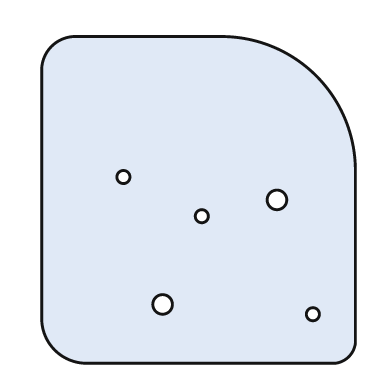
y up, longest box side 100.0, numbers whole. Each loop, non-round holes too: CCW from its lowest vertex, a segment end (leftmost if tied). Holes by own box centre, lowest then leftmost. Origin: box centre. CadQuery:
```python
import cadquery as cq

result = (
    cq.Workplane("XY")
    .moveTo(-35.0, -50.0)
    .lineTo(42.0, -50.0)
    .threePointArc((46.0, -48.0), (48.0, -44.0))
    .lineTo(48.0, 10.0)
    .threePointArc((36.0, 38.0), (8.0, 50.0))
    .lineTo(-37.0, 50.0)
    .threePointArc((-45.0, 47.0), (-48.0, 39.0))
    .lineTo(-48.0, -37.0)
    .threePointArc((-44.0, -46.0), (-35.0, -50.0))
    .close()
    .moveTo(35.0, -35.0)
    .circle(2.0)
    .moveTo(-11.0, -32.0)
    .circle(3.0)
    .moveTo(1.0, -5.0)
    .circle(2.0)
    .moveTo(24.0, 0.0)
    .circle(3.0)
    .moveTo(-23.0, 7.0)
    .circle(2.0)
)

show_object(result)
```